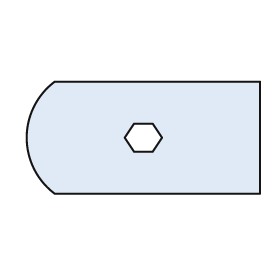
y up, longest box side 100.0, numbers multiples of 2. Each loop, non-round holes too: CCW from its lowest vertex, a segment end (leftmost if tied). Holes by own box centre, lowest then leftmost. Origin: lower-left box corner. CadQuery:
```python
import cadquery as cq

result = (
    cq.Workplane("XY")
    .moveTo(12.0, 0.0)
    .lineTo(100.0, 0.0)
    .lineTo(100.0, 48.0)
    .lineTo(12.0, 48.0)
    .threePointArc((0.0, 24.0), (12.0, 0.0))
    .close()
    .moveTo(46.0, 18.0)
    .lineTo(54.0, 18.0)
    .lineTo(58.0, 24.0)
    .lineTo(54.0, 30.0)
    .lineTo(46.0, 30.0)
    .lineTo(42.0, 24.0)
    .close()
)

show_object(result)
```